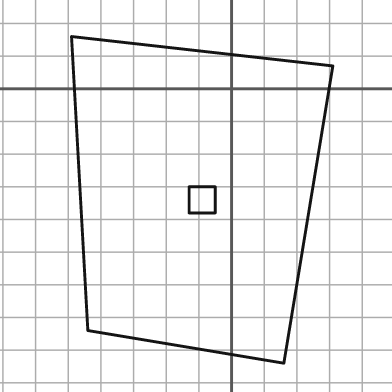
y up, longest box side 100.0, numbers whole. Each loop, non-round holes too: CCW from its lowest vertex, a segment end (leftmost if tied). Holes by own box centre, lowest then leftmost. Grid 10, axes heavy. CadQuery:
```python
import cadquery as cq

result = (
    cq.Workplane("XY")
    .moveTo(16.0, -84.0)
    .lineTo(31.0, 7.0)
    .lineTo(-49.0, 16.0)
    .lineTo(-44.0, -74.0)
    .close()
    .moveTo(-13.0, -38.0)
    .lineTo(-5.0, -38.0)
    .lineTo(-5.0, -30.0)
    .lineTo(-13.0, -30.0)
    .close()
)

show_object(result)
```